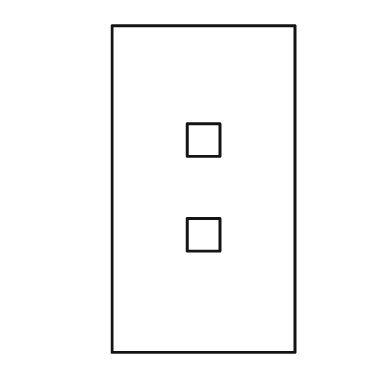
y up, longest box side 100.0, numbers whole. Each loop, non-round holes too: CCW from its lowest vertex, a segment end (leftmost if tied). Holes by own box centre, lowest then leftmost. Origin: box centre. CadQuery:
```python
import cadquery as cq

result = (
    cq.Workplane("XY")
    .moveTo(-28.0, -50.0)
    .lineTo(28.0, -50.0)
    .lineTo(28.0, 50.0)
    .lineTo(-28.0, 50.0)
    .close()
    .moveTo(-5.0, -19.0)
    .lineTo(5.0, -19.0)
    .lineTo(5.0, -9.0)
    .lineTo(-5.0, -9.0)
    .close()
    .moveTo(-5.0, 10.0)
    .lineTo(5.0, 10.0)
    .lineTo(5.0, 20.0)
    .lineTo(-5.0, 20.0)
    .close()
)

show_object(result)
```